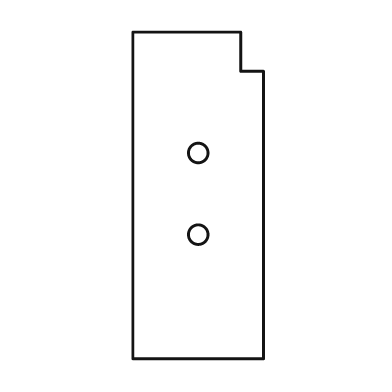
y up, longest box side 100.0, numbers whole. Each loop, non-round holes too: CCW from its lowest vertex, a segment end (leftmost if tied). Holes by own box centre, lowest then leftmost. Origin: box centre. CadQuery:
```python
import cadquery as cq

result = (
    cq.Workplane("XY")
    .moveTo(-20.0, -50.0)
    .lineTo(20.0, -50.0)
    .lineTo(20.0, 38.0)
    .lineTo(13.0, 38.0)
    .lineTo(13.0, 50.0)
    .lineTo(-20.0, 50.0)
    .close()
    .moveTo(0.0, -12.0)
    .circle(3.0)
    .moveTo(0.0, 13.0)
    .circle(3.0)
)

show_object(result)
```